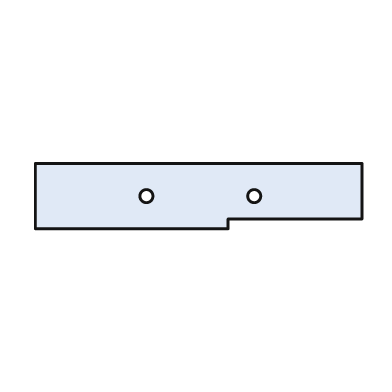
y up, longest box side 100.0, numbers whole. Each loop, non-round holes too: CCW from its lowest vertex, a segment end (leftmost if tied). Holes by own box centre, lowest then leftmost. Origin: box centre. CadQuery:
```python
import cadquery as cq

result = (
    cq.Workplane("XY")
    .moveTo(-50.0, -10.0)
    .lineTo(9.0, -10.0)
    .lineTo(9.0, -7.0)
    .lineTo(50.0, -7.0)
    .lineTo(50.0, 10.0)
    .lineTo(-50.0, 10.0)
    .close()
    .moveTo(-16.0, 0.0)
    .circle(2.0)
    .moveTo(17.0, 0.0)
    .circle(2.0)
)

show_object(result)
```